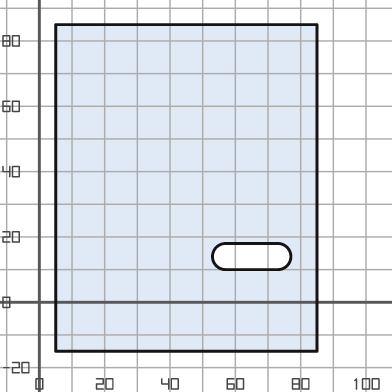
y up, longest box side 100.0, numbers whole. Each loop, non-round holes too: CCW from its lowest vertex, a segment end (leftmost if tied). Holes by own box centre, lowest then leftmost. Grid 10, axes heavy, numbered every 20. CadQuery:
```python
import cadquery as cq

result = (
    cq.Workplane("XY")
    .moveTo(5.0, -15.0)
    .lineTo(85.0, -15.0)
    .lineTo(85.0, 85.0)
    .lineTo(5.0, 85.0)
    .close()
    .moveTo(57.0, 10.0)
    .lineTo(73.0, 10.0)
    .threePointArc((77.0, 14.0), (73.0, 18.0))
    .lineTo(57.0, 18.0)
    .threePointArc((53.0, 14.0), (57.0, 10.0))
    .close()
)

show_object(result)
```